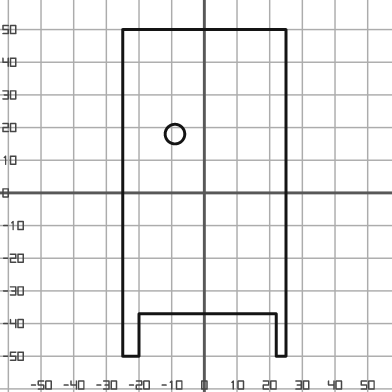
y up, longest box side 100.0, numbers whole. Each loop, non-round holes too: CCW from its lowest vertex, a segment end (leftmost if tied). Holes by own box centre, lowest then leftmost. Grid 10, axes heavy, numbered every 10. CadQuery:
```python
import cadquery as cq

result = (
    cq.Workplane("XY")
    .moveTo(-25.0, -50.0)
    .lineTo(-20.0, -50.0)
    .lineTo(-20.0, -37.0)
    .lineTo(22.0, -37.0)
    .lineTo(22.0, -50.0)
    .lineTo(25.0, -50.0)
    .lineTo(25.0, 50.0)
    .lineTo(-25.0, 50.0)
    .close()
    .moveTo(-9.0, 18.0)
    .circle(3.0)
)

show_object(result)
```